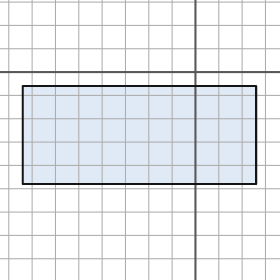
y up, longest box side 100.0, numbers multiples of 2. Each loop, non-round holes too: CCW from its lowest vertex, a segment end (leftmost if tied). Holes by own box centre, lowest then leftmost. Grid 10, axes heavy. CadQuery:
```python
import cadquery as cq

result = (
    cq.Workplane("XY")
    .moveTo(-74.0, -48.0)
    .lineTo(26.0, -48.0)
    .lineTo(26.0, -6.0)
    .lineTo(-74.0, -6.0)
    .close()
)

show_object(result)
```